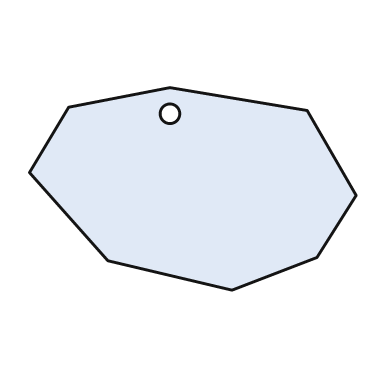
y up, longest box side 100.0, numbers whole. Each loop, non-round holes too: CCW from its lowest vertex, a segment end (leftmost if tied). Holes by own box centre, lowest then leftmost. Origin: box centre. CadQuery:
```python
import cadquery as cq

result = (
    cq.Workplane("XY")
    .moveTo(12.0, -31.0)
    .lineTo(38.0, -21.0)
    .lineTo(50.0, -2.0)
    .lineTo(35.0, 24.0)
    .lineTo(-7.0, 31.0)
    .lineTo(-38.0, 25.0)
    .lineTo(-50.0, 5.0)
    .lineTo(-26.0, -22.0)
    .close()
    .moveTo(-7.0, 23.0)
    .circle(3.0)
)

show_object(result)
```